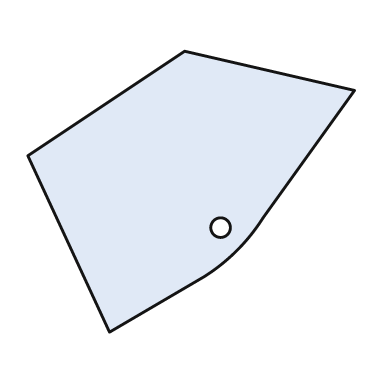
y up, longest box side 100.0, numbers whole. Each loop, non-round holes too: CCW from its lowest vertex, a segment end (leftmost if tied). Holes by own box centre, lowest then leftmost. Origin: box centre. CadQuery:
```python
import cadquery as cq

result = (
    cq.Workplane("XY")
    .moveTo(-25.0, -43.0)
    .lineTo(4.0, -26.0)
    .threePointArc((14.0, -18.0), (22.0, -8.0))
    .lineTo(50.0, 31.0)
    .lineTo(-2.0, 43.0)
    .lineTo(-50.0, 11.0)
    .close()
    .moveTo(9.0, -11.0)
    .circle(3.0)
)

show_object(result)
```